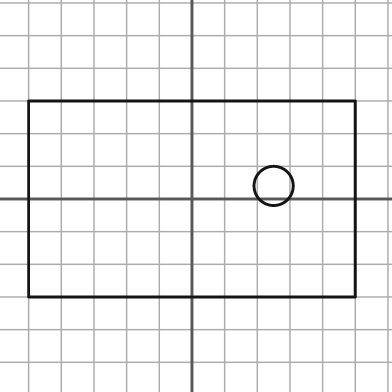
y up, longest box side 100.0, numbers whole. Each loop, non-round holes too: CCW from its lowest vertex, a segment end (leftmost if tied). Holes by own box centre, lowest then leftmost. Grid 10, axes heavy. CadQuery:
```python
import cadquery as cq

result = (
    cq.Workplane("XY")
    .moveTo(-50.0, -30.0)
    .lineTo(50.0, -30.0)
    .lineTo(50.0, 30.0)
    .lineTo(-50.0, 30.0)
    .close()
    .moveTo(25.0, 4.0)
    .circle(6.0)
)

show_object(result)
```